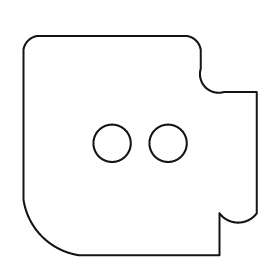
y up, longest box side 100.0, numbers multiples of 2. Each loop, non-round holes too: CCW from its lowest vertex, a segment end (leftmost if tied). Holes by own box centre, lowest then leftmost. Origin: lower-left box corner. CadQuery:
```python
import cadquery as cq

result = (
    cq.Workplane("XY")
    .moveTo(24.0, 0.0)
    .lineTo(84.0, 0.0)
    .lineTo(84.0, 18.0)
    .threePointArc((92.0, 14.0), (100.0, 18.0))
    .lineTo(100.0, 70.0)
    .lineTo(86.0, 70.0)
    .threePointArc((78.0, 72.0), (76.0, 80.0))
    .lineTo(76.0, 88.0)
    .threePointArc((74.0, 92.0), (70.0, 94.0))
    .lineTo(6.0, 94.0)
    .threePointArc((2.0, 92.0), (0.0, 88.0))
    .lineTo(0.0, 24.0)
    .threePointArc((8.0, 8.0), (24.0, 0.0))
    .close()
    .moveTo(38.0, 48.0)
    .circle(8.0)
    .moveTo(62.0, 48.0)
    .circle(8.0)
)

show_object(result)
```